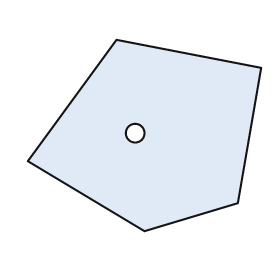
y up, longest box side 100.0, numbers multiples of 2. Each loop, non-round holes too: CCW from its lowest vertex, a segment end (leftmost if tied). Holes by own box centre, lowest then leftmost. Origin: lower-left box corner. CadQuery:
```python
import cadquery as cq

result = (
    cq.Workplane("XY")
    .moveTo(50.0, 0.0)
    .lineTo(90.0, 12.0)
    .lineTo(100.0, 70.0)
    .lineTo(38.0, 82.0)
    .lineTo(0.0, 30.0)
    .close()
    .moveTo(46.0, 42.0)
    .circle(4.0)
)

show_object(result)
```